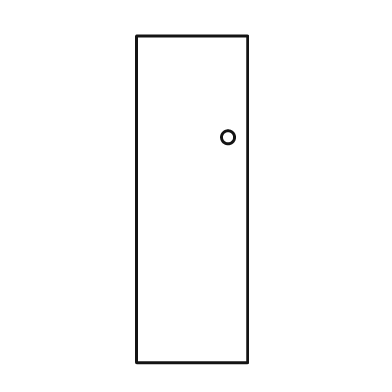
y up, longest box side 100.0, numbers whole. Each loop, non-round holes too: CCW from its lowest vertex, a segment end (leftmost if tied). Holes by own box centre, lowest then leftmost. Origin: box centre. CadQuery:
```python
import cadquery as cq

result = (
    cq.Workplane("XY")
    .moveTo(-17.0, -50.0)
    .lineTo(17.0, -50.0)
    .lineTo(17.0, 50.0)
    .lineTo(-17.0, 50.0)
    .close()
    .moveTo(11.0, 19.0)
    .circle(2.0)
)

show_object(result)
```